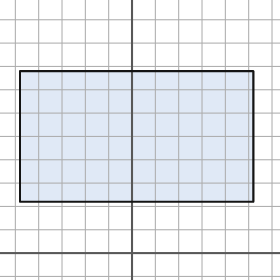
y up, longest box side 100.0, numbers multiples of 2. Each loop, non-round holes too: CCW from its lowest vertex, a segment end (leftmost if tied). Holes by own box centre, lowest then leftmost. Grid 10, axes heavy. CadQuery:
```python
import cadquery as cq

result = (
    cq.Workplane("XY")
    .moveTo(-48.0, 22.0)
    .lineTo(52.0, 22.0)
    .lineTo(52.0, 78.0)
    .lineTo(-48.0, 78.0)
    .close()
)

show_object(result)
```